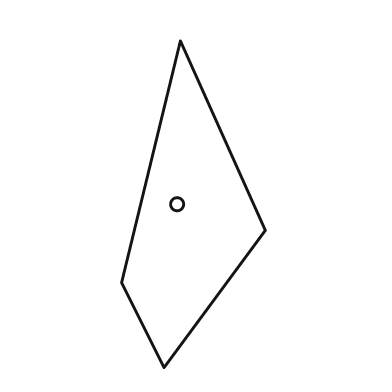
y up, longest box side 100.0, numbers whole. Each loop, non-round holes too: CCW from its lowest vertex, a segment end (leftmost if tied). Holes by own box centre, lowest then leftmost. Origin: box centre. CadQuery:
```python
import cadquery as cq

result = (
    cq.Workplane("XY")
    .moveTo(-9.0, -50.0)
    .lineTo(22.0, -8.0)
    .lineTo(-4.0, 50.0)
    .lineTo(-22.0, -24.0)
    .close()
    .moveTo(-5.0, 0.0)
    .circle(2.0)
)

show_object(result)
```